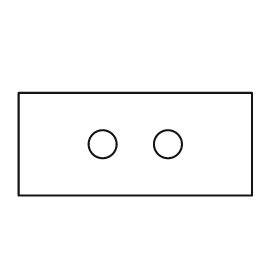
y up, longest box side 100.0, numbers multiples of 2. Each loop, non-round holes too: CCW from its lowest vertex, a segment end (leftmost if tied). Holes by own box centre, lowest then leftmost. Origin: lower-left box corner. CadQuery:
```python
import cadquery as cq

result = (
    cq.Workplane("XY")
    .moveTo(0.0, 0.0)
    .lineTo(100.0, 0.0)
    .lineTo(100.0, 44.0)
    .lineTo(0.0, 44.0)
    .close()
    .moveTo(36.0, 22.0)
    .circle(6.0)
    .moveTo(64.0, 22.0)
    .circle(6.0)
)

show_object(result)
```